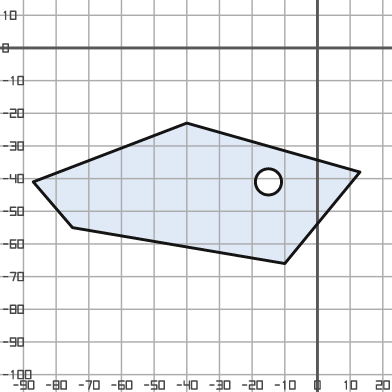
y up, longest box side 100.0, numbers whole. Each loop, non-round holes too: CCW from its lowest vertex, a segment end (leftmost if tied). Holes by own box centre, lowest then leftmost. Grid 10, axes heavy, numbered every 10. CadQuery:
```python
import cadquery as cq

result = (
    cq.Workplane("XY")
    .moveTo(-10.0, -66.0)
    .lineTo(13.0, -38.0)
    .lineTo(-40.0, -23.0)
    .lineTo(-87.0, -41.0)
    .lineTo(-75.0, -55.0)
    .close()
    .moveTo(-15.0, -41.0)
    .circle(4.0)
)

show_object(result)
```